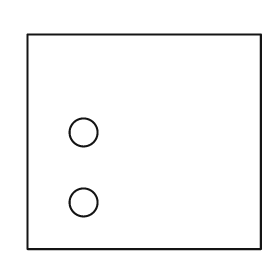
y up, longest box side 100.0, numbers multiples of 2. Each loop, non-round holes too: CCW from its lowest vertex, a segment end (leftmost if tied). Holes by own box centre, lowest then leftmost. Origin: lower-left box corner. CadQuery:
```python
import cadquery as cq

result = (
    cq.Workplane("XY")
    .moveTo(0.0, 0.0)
    .lineTo(100.0, 0.0)
    .lineTo(100.0, 92.0)
    .lineTo(0.0, 92.0)
    .close()
    .moveTo(24.0, 20.0)
    .circle(6.0)
    .moveTo(24.0, 50.0)
    .circle(6.0)
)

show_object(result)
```